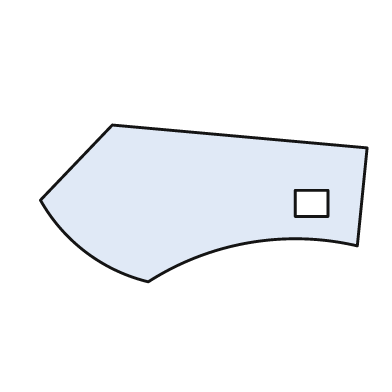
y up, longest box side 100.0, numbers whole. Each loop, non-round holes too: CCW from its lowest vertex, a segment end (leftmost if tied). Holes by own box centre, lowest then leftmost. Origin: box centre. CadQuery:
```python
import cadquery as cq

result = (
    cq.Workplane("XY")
    .moveTo(-17.0, -24.0)
    .threePointArc((14.0, -12.0), (47.0, -13.0))
    .lineTo(50.0, 17.0)
    .lineTo(-28.0, 24.0)
    .lineTo(-50.0, 1.0)
    .threePointArc((-36.0, -15.0), (-17.0, -24.0))
    .close()
    .moveTo(28.0, -4.0)
    .lineTo(38.0, -4.0)
    .lineTo(38.0, 4.0)
    .lineTo(28.0, 4.0)
    .close()
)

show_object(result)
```